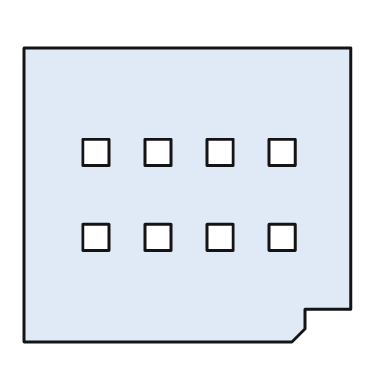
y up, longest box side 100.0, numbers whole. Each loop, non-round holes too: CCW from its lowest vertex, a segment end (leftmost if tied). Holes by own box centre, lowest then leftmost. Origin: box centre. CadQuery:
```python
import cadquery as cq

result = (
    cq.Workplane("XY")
    .moveTo(-50.0, -45.0)
    .lineTo(32.0, -45.0)
    .lineTo(36.0, -41.0)
    .lineTo(36.0, -35.0)
    .lineTo(50.0, -35.0)
    .lineTo(50.0, 45.0)
    .lineTo(-50.0, 45.0)
    .close()
    .moveTo(-32.0, -17.0)
    .lineTo(-24.0, -17.0)
    .lineTo(-24.0, -9.0)
    .lineTo(-32.0, -9.0)
    .close()
    .moveTo(-13.0, -17.0)
    .lineTo(-5.0, -17.0)
    .lineTo(-5.0, -9.0)
    .lineTo(-13.0, -9.0)
    .close()
    .moveTo(6.0, -17.0)
    .lineTo(14.0, -17.0)
    .lineTo(14.0, -9.0)
    .lineTo(6.0, -9.0)
    .close()
    .moveTo(25.0, -17.0)
    .lineTo(33.0, -17.0)
    .lineTo(33.0, -9.0)
    .lineTo(25.0, -9.0)
    .close()
    .moveTo(-32.0, 9.0)
    .lineTo(-24.0, 9.0)
    .lineTo(-24.0, 17.0)
    .lineTo(-32.0, 17.0)
    .close()
    .moveTo(-13.0, 9.0)
    .lineTo(-5.0, 9.0)
    .lineTo(-5.0, 17.0)
    .lineTo(-13.0, 17.0)
    .close()
    .moveTo(6.0, 9.0)
    .lineTo(14.0, 9.0)
    .lineTo(14.0, 17.0)
    .lineTo(6.0, 17.0)
    .close()
    .moveTo(25.0, 9.0)
    .lineTo(33.0, 9.0)
    .lineTo(33.0, 17.0)
    .lineTo(25.0, 17.0)
    .close()
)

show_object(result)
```